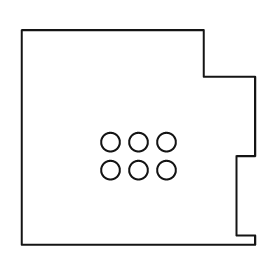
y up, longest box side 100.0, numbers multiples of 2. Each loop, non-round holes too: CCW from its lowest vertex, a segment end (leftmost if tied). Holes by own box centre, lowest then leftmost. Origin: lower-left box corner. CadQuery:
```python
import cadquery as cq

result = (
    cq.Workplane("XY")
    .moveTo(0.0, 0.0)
    .lineTo(100.0, 0.0)
    .lineTo(100.0, 4.0)
    .lineTo(92.0, 4.0)
    .lineTo(92.0, 38.0)
    .lineTo(100.0, 38.0)
    .lineTo(100.0, 72.0)
    .lineTo(78.0, 72.0)
    .lineTo(78.0, 92.0)
    .lineTo(0.0, 92.0)
    .close()
    .moveTo(38.0, 32.0)
    .circle(4.0)
    .moveTo(50.0, 32.0)
    .circle(4.0)
    .moveTo(62.0, 32.0)
    .circle(4.0)
    .moveTo(38.0, 44.0)
    .circle(4.0)
    .moveTo(50.0, 44.0)
    .circle(4.0)
    .moveTo(62.0, 44.0)
    .circle(4.0)
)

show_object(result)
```